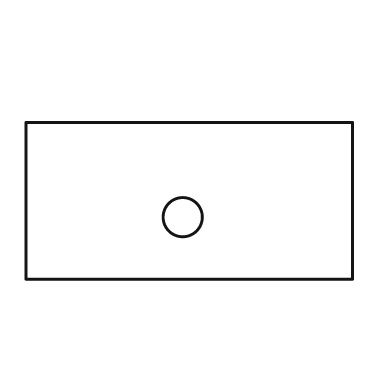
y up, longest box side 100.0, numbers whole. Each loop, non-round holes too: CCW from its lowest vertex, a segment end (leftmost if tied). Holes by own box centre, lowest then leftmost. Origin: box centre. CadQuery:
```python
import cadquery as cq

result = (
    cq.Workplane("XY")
    .moveTo(-50.0, -24.0)
    .lineTo(50.0, -24.0)
    .lineTo(50.0, 24.0)
    .lineTo(-50.0, 24.0)
    .close()
    .moveTo(-2.0, -5.0)
    .circle(6.0)
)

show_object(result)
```